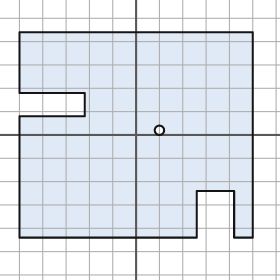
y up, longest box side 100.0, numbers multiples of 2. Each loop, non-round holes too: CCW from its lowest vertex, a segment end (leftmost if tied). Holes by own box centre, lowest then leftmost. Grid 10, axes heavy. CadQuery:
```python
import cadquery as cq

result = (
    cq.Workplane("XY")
    .moveTo(-50.0, -44.0)
    .lineTo(26.0, -44.0)
    .lineTo(26.0, -24.0)
    .lineTo(42.0, -24.0)
    .lineTo(42.0, -44.0)
    .lineTo(50.0, -44.0)
    .lineTo(50.0, 44.0)
    .lineTo(-50.0, 44.0)
    .lineTo(-50.0, 18.0)
    .lineTo(-22.0, 18.0)
    .lineTo(-22.0, 8.0)
    .lineTo(-50.0, 8.0)
    .close()
    .moveTo(10.0, 2.0)
    .circle(2.0)
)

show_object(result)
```